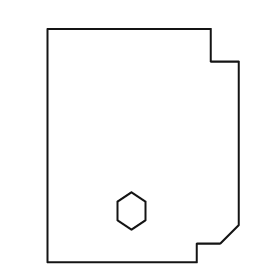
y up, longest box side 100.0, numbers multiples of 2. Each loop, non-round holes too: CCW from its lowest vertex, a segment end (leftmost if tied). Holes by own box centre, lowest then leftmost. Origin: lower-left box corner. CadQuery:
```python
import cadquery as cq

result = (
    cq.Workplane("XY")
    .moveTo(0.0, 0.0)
    .lineTo(64.0, 0.0)
    .lineTo(64.0, 8.0)
    .lineTo(74.0, 8.0)
    .lineTo(82.0, 16.0)
    .lineTo(82.0, 86.0)
    .lineTo(70.0, 86.0)
    .lineTo(70.0, 100.0)
    .lineTo(0.0, 100.0)
    .close()
    .moveTo(36.0, 14.0)
    .lineTo(42.0, 18.0)
    .lineTo(42.0, 26.0)
    .lineTo(36.0, 30.0)
    .lineTo(30.0, 26.0)
    .lineTo(30.0, 18.0)
    .close()
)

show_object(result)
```